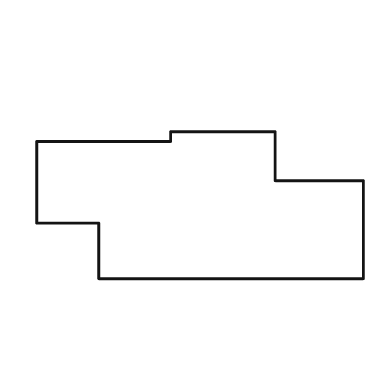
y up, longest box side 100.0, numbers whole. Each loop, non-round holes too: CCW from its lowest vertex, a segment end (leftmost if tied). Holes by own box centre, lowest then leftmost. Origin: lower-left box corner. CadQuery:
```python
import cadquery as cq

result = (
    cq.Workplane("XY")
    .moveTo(19.0, 0.0)
    .lineTo(100.0, 0.0)
    .lineTo(100.0, 30.0)
    .lineTo(73.0, 30.0)
    .lineTo(73.0, 45.0)
    .lineTo(41.0, 45.0)
    .lineTo(41.0, 42.0)
    .lineTo(0.0, 42.0)
    .lineTo(0.0, 17.0)
    .lineTo(19.0, 17.0)
    .close()
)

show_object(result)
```